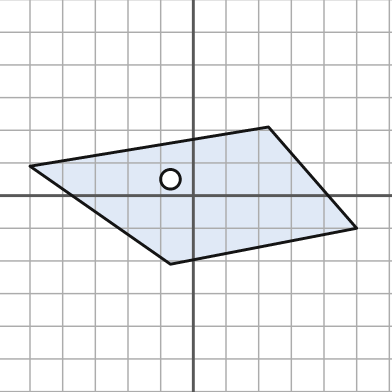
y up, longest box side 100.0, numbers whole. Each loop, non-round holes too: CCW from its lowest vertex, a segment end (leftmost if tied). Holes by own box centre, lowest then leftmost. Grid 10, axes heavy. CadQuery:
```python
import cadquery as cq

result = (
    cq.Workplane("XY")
    .moveTo(-7.0, -21.0)
    .lineTo(50.0, -10.0)
    .lineTo(23.0, 21.0)
    .lineTo(-50.0, 9.0)
    .close()
    .moveTo(-7.0, 5.0)
    .circle(3.0)
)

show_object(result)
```